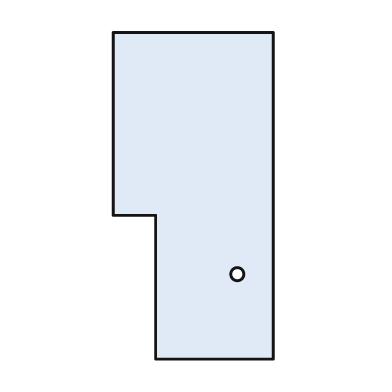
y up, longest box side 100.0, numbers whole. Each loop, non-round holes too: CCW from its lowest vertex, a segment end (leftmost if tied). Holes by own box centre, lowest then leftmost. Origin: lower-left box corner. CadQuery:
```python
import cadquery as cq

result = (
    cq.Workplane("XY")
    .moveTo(13.0, 0.0)
    .lineTo(49.0, 0.0)
    .lineTo(49.0, 100.0)
    .lineTo(0.0, 100.0)
    .lineTo(0.0, 44.0)
    .lineTo(13.0, 44.0)
    .close()
    .moveTo(38.0, 26.0)
    .circle(2.0)
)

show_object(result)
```